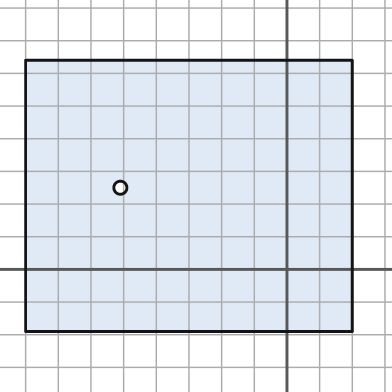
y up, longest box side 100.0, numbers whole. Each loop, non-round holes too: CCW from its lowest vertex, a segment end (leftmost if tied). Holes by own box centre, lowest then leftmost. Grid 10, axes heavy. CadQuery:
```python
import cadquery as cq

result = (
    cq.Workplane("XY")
    .moveTo(-80.0, -19.0)
    .lineTo(20.0, -19.0)
    .lineTo(20.0, 64.0)
    .lineTo(-80.0, 64.0)
    .close()
    .moveTo(-51.0, 25.0)
    .circle(2.0)
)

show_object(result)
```